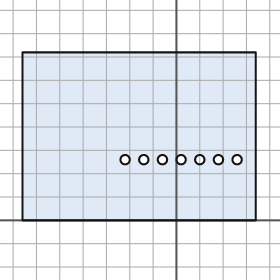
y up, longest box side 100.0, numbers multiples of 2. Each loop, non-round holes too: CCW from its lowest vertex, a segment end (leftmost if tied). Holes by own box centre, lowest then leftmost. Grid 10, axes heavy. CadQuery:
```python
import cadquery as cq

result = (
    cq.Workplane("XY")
    .moveTo(-66.0, 0.0)
    .lineTo(34.0, 0.0)
    .lineTo(34.0, 72.0)
    .lineTo(-66.0, 72.0)
    .close()
    .moveTo(-22.0, 26.0)
    .circle(2.0)
    .moveTo(-14.0, 26.0)
    .circle(2.0)
    .moveTo(-6.0, 26.0)
    .circle(2.0)
    .moveTo(2.0, 26.0)
    .circle(2.0)
    .moveTo(10.0, 26.0)
    .circle(2.0)
    .moveTo(18.0, 26.0)
    .circle(2.0)
    .moveTo(26.0, 26.0)
    .circle(2.0)
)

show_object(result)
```